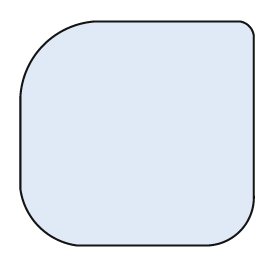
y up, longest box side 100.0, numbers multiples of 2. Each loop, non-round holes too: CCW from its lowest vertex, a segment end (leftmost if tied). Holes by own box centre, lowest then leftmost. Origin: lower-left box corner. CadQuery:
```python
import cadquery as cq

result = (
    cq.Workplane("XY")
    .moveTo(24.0, 0.0)
    .lineTo(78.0, 0.0)
    .threePointArc((94.0, 6.0), (100.0, 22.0))
    .lineTo(100.0, 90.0)
    .threePointArc((98.0, 94.0), (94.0, 96.0))
    .lineTo(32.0, 96.0)
    .threePointArc((10.0, 86.0), (0.0, 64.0))
    .lineTo(0.0, 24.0)
    .threePointArc((8.0, 8.0), (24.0, 0.0))
    .close()
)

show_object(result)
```